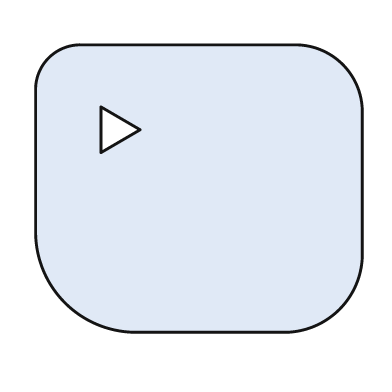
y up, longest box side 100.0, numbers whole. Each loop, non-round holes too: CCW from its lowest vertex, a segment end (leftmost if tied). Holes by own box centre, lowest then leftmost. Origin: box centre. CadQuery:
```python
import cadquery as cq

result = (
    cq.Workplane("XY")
    .moveTo(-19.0, -44.0)
    .lineTo(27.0, -44.0)
    .threePointArc((43.0, -37.0), (50.0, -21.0))
    .lineTo(50.0, 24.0)
    .threePointArc((44.0, 38.0), (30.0, 44.0))
    .lineTo(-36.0, 44.0)
    .threePointArc((-46.0, 40.0), (-50.0, 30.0))
    .lineTo(-50.0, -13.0)
    .threePointArc((-41.0, -35.0), (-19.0, -44.0))
    .close()
    .moveTo(-30.0, 11.0)
    .lineTo(-18.0, 18.0)
    .lineTo(-30.0, 25.0)
    .close()
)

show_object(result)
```